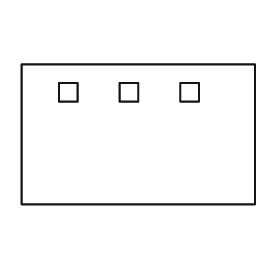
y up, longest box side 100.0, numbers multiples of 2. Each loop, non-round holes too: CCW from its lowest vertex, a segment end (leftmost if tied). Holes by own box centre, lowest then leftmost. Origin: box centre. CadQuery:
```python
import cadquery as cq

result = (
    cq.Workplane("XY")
    .moveTo(-50.0, -30.0)
    .lineTo(50.0, -30.0)
    .lineTo(50.0, 30.0)
    .lineTo(-50.0, 30.0)
    .close()
    .moveTo(-34.0, 14.0)
    .lineTo(-26.0, 14.0)
    .lineTo(-26.0, 22.0)
    .lineTo(-34.0, 22.0)
    .close()
    .moveTo(-8.0, 14.0)
    .lineTo(0.0, 14.0)
    .lineTo(0.0, 22.0)
    .lineTo(-8.0, 22.0)
    .close()
    .moveTo(18.0, 14.0)
    .lineTo(26.0, 14.0)
    .lineTo(26.0, 22.0)
    .lineTo(18.0, 22.0)
    .close()
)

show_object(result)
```